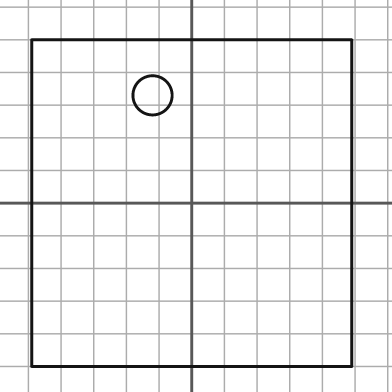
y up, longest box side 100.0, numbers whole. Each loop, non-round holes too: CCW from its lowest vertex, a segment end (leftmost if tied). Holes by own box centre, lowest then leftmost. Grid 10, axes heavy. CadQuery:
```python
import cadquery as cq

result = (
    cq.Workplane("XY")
    .moveTo(-49.0, -50.0)
    .lineTo(49.0, -50.0)
    .lineTo(49.0, 50.0)
    .lineTo(-49.0, 50.0)
    .close()
    .moveTo(-12.0, 33.0)
    .circle(6.0)
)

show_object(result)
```